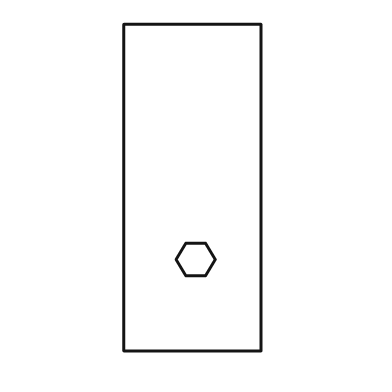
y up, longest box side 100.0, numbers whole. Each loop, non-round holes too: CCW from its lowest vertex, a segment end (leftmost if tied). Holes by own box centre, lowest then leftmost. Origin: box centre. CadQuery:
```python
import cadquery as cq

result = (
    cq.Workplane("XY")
    .moveTo(-21.0, -50.0)
    .lineTo(21.0, -50.0)
    .lineTo(21.0, 50.0)
    .lineTo(-21.0, 50.0)
    .close()
    .moveTo(-2.0, -27.0)
    .lineTo(4.0, -27.0)
    .lineTo(7.0, -22.0)
    .lineTo(4.0, -17.0)
    .lineTo(-2.0, -17.0)
    .lineTo(-5.0, -22.0)
    .close()
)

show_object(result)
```